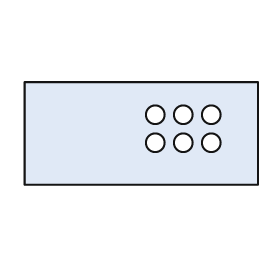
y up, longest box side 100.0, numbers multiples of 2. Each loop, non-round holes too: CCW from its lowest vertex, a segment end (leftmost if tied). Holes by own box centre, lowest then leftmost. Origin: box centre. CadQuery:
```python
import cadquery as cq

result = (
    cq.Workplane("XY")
    .moveTo(-50.0, -22.0)
    .lineTo(50.0, -22.0)
    .lineTo(50.0, 22.0)
    .lineTo(-50.0, 22.0)
    .close()
    .moveTo(6.0, -4.0)
    .circle(4.0)
    .moveTo(18.0, -4.0)
    .circle(4.0)
    .moveTo(30.0, -4.0)
    .circle(4.0)
    .moveTo(6.0, 8.0)
    .circle(4.0)
    .moveTo(18.0, 8.0)
    .circle(4.0)
    .moveTo(30.0, 8.0)
    .circle(4.0)
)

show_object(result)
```